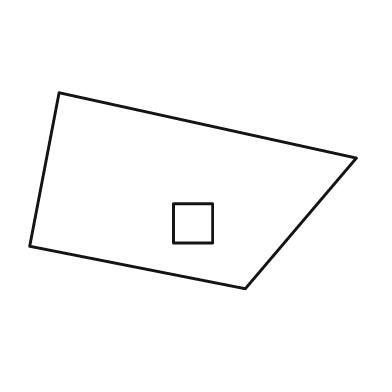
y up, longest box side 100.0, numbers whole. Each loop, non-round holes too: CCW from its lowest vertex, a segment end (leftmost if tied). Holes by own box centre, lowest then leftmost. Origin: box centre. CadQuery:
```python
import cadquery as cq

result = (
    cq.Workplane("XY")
    .moveTo(16.0, -30.0)
    .lineTo(50.0, 10.0)
    .lineTo(-41.0, 30.0)
    .lineTo(-50.0, -17.0)
    .close()
    .moveTo(-6.0, -16.0)
    .lineTo(6.0, -16.0)
    .lineTo(6.0, -4.0)
    .lineTo(-6.0, -4.0)
    .close()
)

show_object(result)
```